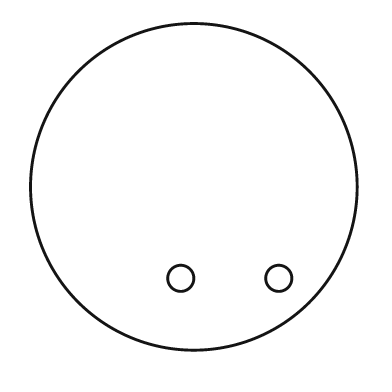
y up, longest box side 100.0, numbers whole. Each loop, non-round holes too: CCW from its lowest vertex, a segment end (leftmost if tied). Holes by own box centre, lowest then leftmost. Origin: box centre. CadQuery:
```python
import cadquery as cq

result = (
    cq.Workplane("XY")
    .moveTo(0.0, 0.0)
    .circle(50.0)
    .moveTo(-4.0, -28.0)
    .circle(4.0)
    .moveTo(26.0, -28.0)
    .circle(4.0)
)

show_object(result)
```